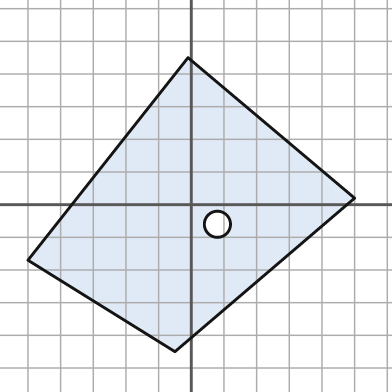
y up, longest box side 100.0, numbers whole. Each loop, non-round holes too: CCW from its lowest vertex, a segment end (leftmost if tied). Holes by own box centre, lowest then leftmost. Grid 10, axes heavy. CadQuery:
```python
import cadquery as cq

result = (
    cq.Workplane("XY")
    .moveTo(-5.0, -45.0)
    .lineTo(50.0, 2.0)
    .lineTo(-1.0, 45.0)
    .lineTo(-50.0, -17.0)
    .close()
    .moveTo(8.0, -6.0)
    .circle(4.0)
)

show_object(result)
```